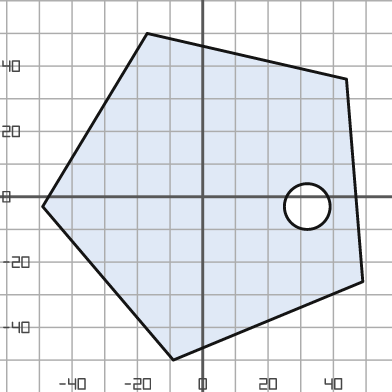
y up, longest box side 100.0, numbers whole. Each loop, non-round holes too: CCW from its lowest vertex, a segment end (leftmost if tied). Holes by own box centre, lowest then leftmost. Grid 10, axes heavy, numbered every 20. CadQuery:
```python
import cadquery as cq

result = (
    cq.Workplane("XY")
    .moveTo(-9.0, -50.0)
    .lineTo(49.0, -26.0)
    .lineTo(44.0, 36.0)
    .lineTo(-17.0, 50.0)
    .lineTo(-49.0, -3.0)
    .close()
    .moveTo(32.0, -3.0)
    .circle(7.0)
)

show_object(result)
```